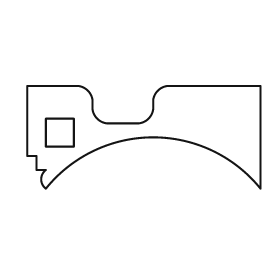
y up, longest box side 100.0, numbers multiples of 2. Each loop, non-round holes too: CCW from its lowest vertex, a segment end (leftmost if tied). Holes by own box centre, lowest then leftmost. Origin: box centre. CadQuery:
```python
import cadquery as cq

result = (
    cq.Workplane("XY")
    .moveTo(-42.0, -22.0)
    .threePointArc((4.0, 0.0), (50.0, -22.0))
    .lineTo(50.0, 22.0)
    .lineTo(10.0, 22.0)
    .threePointArc((6.0, 20.0), (4.0, 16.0))
    .lineTo(4.0, 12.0)
    .threePointArc((2.0, 8.0), (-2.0, 6.0))
    .lineTo(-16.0, 6.0)
    .threePointArc((-20.0, 8.0), (-22.0, 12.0))
    .lineTo(-22.0, 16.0)
    .threePointArc((-24.0, 20.0), (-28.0, 22.0))
    .lineTo(-50.0, 22.0)
    .lineTo(-50.0, -8.0)
    .lineTo(-46.0, -8.0)
    .lineTo(-46.0, -14.0)
    .lineTo(-42.0, -14.0)
    .threePointArc((-44.0, -18.0), (-42.0, -22.0))
    .close()
    .moveTo(-42.0, -4.0)
    .lineTo(-30.0, -4.0)
    .lineTo(-30.0, 8.0)
    .lineTo(-42.0, 8.0)
    .close()
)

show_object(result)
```